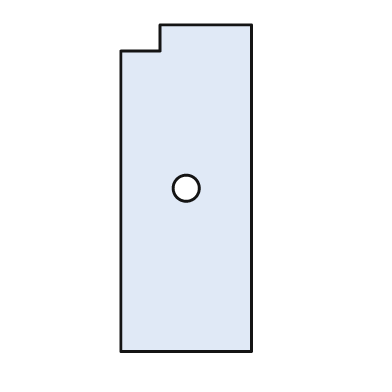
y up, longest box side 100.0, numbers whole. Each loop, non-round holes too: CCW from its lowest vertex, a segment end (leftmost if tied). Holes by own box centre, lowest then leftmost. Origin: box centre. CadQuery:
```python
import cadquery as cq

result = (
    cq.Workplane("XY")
    .moveTo(-20.0, -50.0)
    .lineTo(20.0, -50.0)
    .lineTo(20.0, 50.0)
    .lineTo(-8.0, 50.0)
    .lineTo(-8.0, 42.0)
    .lineTo(-20.0, 42.0)
    .close()
    .moveTo(0.0, 0.0)
    .circle(4.0)
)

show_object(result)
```